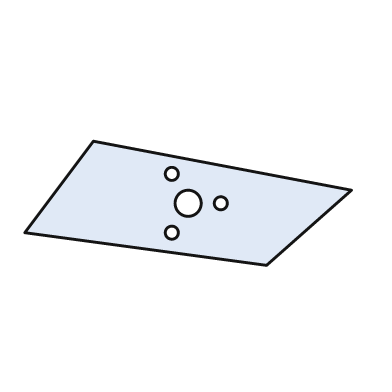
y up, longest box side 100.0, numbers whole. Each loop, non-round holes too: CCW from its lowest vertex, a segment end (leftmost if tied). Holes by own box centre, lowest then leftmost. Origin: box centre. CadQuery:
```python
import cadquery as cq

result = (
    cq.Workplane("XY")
    .moveTo(24.0, -19.0)
    .lineTo(50.0, 4.0)
    .lineTo(-29.0, 19.0)
    .lineTo(-50.0, -9.0)
    .close()
    .moveTo(-5.0, -9.0)
    .circle(2.0)
    .moveTo(0.0, 0.0)
    .circle(4.0)
    .moveTo(10.0, 0.0)
    .circle(2.0)
    .moveTo(-5.0, 9.0)
    .circle(2.0)
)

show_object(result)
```